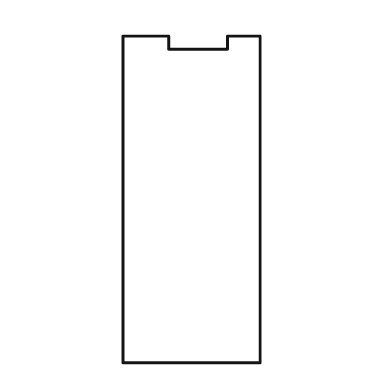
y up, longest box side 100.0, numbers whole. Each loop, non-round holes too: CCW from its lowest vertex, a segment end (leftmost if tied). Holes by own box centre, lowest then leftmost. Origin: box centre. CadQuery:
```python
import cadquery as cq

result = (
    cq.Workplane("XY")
    .moveTo(-21.0, -50.0)
    .lineTo(21.0, -50.0)
    .lineTo(21.0, 50.0)
    .lineTo(11.0, 50.0)
    .lineTo(11.0, 46.0)
    .lineTo(-7.0, 46.0)
    .lineTo(-7.0, 50.0)
    .lineTo(-21.0, 50.0)
    .close()
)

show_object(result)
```